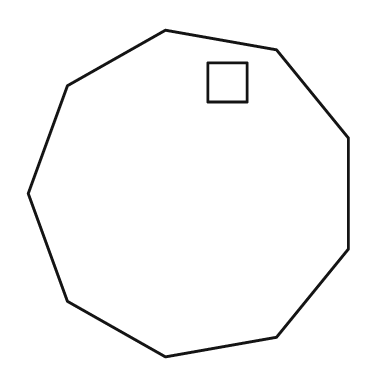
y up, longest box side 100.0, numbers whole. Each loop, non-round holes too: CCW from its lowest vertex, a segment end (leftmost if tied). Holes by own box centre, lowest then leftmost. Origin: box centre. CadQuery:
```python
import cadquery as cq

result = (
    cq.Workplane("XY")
    .moveTo(-7.0, -50.0)
    .lineTo(27.0, -44.0)
    .lineTo(49.0, -17.0)
    .lineTo(49.0, 17.0)
    .lineTo(27.0, 44.0)
    .lineTo(-7.0, 50.0)
    .lineTo(-37.0, 33.0)
    .lineTo(-49.0, 0.0)
    .lineTo(-37.0, -33.0)
    .close()
    .moveTo(6.0, 28.0)
    .lineTo(18.0, 28.0)
    .lineTo(18.0, 40.0)
    .lineTo(6.0, 40.0)
    .close()
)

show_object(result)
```